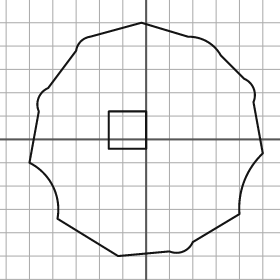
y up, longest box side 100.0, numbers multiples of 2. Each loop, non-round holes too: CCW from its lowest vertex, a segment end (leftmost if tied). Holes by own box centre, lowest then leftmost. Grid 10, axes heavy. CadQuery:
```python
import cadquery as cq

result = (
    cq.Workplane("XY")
    .moveTo(-12.0, -50.0)
    .lineTo(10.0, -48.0)
    .threePointArc((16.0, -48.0), (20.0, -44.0))
    .lineTo(40.0, -32.0)
    .threePointArc((42.0, -18.0), (50.0, -6.0))
    .lineTo(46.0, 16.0)
    .threePointArc((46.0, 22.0), (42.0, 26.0))
    .lineTo(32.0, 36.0)
    .threePointArc((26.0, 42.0), (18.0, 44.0))
    .lineTo(-2.0, 50.0)
    .lineTo(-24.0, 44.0)
    .threePointArc((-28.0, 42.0), (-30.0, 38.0))
    .lineTo(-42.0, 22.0)
    .threePointArc((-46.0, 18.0), (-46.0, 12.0))
    .lineTo(-50.0, -10.0)
    .threePointArc((-40.0, -20.0), (-38.0, -34.0))
    .close()
    .moveTo(-16.0, -4.0)
    .lineTo(0.0, -4.0)
    .lineTo(0.0, 12.0)
    .lineTo(-16.0, 12.0)
    .close()
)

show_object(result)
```